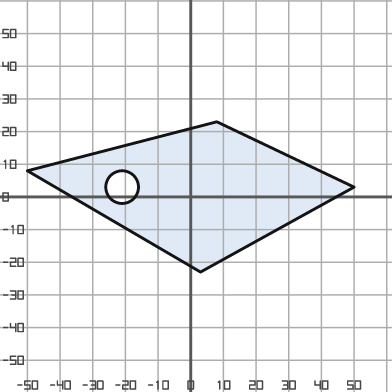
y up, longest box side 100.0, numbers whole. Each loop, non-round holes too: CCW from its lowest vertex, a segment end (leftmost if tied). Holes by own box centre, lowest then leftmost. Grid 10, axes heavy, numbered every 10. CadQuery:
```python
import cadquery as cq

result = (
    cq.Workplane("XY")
    .moveTo(3.0, -23.0)
    .lineTo(50.0, 3.0)
    .lineTo(8.0, 23.0)
    .lineTo(-50.0, 8.0)
    .close()
    .moveTo(-21.0, 3.0)
    .circle(5.0)
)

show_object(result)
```